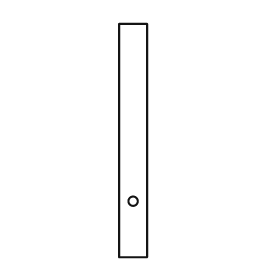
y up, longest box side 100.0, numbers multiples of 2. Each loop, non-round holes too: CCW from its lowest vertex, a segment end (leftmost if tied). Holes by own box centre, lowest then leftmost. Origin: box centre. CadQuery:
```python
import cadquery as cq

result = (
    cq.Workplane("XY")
    .moveTo(-6.0, -50.0)
    .lineTo(6.0, -50.0)
    .lineTo(6.0, 50.0)
    .lineTo(-6.0, 50.0)
    .close()
    .moveTo(0.0, -26.0)
    .circle(2.0)
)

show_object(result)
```